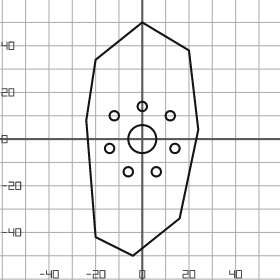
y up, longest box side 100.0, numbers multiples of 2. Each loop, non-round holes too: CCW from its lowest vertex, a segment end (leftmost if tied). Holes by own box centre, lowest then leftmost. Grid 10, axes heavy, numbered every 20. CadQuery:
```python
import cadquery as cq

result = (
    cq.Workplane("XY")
    .moveTo(-4.0, -50.0)
    .lineTo(16.0, -34.0)
    .lineTo(24.0, 4.0)
    .lineTo(20.0, 38.0)
    .lineTo(0.0, 50.0)
    .lineTo(-20.0, 34.0)
    .lineTo(-24.0, 8.0)
    .lineTo(-20.0, -42.0)
    .close()
    .moveTo(-6.0, -14.0)
    .circle(2.0)
    .moveTo(6.0, -14.0)
    .circle(2.0)
    .moveTo(-14.0, -4.0)
    .circle(2.0)
    .moveTo(14.0, -4.0)
    .circle(2.0)
    .moveTo(0.0, 0.0)
    .circle(6.0)
    .moveTo(-12.0, 10.0)
    .circle(2.0)
    .moveTo(12.0, 10.0)
    .circle(2.0)
    .moveTo(0.0, 14.0)
    .circle(2.0)
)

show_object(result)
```